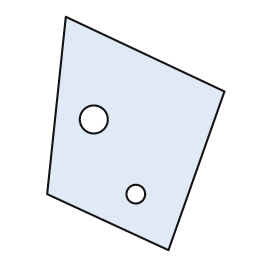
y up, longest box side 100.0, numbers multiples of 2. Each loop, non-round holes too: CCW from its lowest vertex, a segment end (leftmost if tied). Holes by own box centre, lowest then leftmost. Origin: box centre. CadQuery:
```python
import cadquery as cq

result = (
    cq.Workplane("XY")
    .moveTo(14.0, -50.0)
    .lineTo(38.0, 18.0)
    .lineTo(-30.0, 50.0)
    .lineTo(-38.0, -26.0)
    .close()
    .moveTo(0.0, -26.0)
    .circle(4.0)
    .moveTo(-18.0, 6.0)
    .circle(6.0)
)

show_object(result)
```